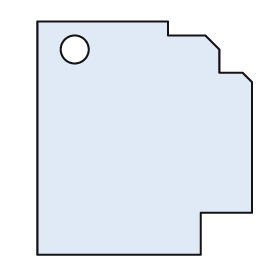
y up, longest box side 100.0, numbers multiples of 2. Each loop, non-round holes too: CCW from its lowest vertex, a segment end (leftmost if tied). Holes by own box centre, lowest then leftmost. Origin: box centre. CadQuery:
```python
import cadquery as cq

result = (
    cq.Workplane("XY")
    .moveTo(-46.0, -50.0)
    .lineTo(24.0, -50.0)
    .lineTo(24.0, -32.0)
    .lineTo(46.0, -32.0)
    .lineTo(46.0, 24.0)
    .lineTo(42.0, 28.0)
    .lineTo(32.0, 28.0)
    .lineTo(32.0, 38.0)
    .lineTo(26.0, 44.0)
    .lineTo(10.0, 44.0)
    .lineTo(10.0, 50.0)
    .lineTo(-46.0, 50.0)
    .close()
    .moveTo(-30.0, 38.0)
    .circle(6.0)
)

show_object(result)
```